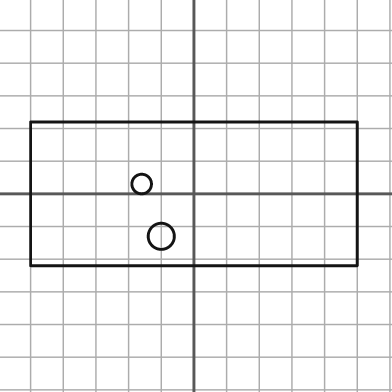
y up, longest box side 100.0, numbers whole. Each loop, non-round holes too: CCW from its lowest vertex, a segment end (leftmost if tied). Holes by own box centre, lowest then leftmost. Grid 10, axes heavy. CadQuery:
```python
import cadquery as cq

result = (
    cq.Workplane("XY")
    .moveTo(-50.0, -22.0)
    .lineTo(50.0, -22.0)
    .lineTo(50.0, 22.0)
    .lineTo(-50.0, 22.0)
    .close()
    .moveTo(-10.0, -13.0)
    .circle(4.0)
    .moveTo(-16.0, 3.0)
    .circle(3.0)
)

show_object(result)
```